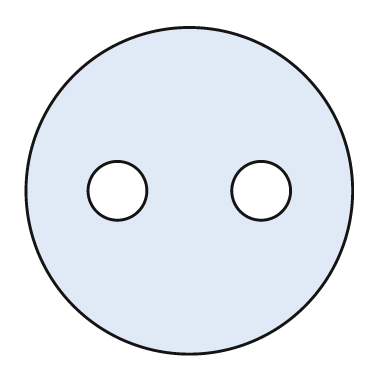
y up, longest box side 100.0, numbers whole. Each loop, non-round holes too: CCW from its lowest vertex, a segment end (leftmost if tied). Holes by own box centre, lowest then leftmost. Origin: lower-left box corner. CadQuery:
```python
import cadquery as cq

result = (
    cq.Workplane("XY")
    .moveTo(50.0, 50.0)
    .circle(50.0)
    .moveTo(28.0, 50.0)
    .circle(9.0)
    .moveTo(72.0, 50.0)
    .circle(9.0)
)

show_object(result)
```